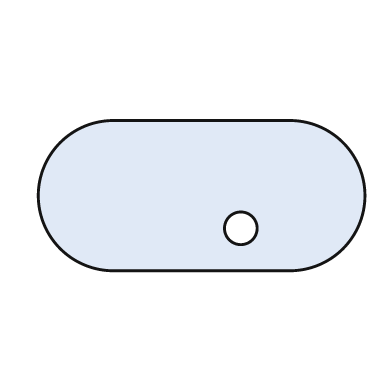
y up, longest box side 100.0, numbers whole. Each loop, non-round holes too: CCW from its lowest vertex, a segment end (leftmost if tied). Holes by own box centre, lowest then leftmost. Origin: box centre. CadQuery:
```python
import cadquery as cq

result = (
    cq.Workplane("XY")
    .moveTo(-27.0, -23.0)
    .lineTo(27.0, -23.0)
    .threePointArc((50.0, 0.0), (27.0, 23.0))
    .lineTo(-27.0, 23.0)
    .threePointArc((-50.0, 0.0), (-27.0, -23.0))
    .close()
    .moveTo(12.0, -10.0)
    .circle(5.0)
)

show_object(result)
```